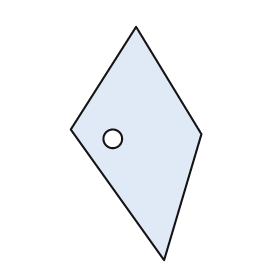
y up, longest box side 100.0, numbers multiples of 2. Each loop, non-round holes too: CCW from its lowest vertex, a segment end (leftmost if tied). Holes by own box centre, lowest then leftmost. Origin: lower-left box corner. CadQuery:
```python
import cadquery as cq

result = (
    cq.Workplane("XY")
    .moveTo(40.0, 0.0)
    .lineTo(56.0, 54.0)
    .lineTo(28.0, 100.0)
    .lineTo(0.0, 56.0)
    .close()
    .moveTo(18.0, 52.0)
    .circle(4.0)
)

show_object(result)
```